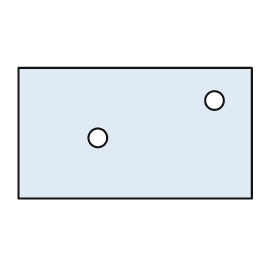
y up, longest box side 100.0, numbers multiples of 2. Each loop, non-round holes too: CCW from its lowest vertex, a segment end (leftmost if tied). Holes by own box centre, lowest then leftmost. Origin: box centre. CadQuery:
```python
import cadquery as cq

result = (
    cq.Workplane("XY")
    .moveTo(-50.0, -28.0)
    .lineTo(50.0, -28.0)
    .lineTo(50.0, 28.0)
    .lineTo(-50.0, 28.0)
    .close()
    .moveTo(-16.0, -2.0)
    .circle(4.0)
    .moveTo(34.0, 14.0)
    .circle(4.0)
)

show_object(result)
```